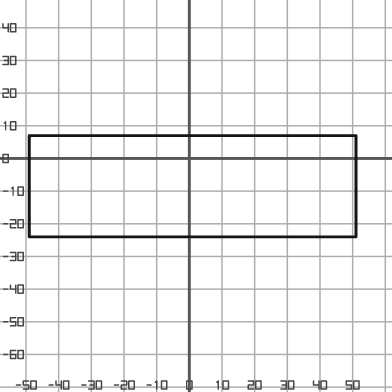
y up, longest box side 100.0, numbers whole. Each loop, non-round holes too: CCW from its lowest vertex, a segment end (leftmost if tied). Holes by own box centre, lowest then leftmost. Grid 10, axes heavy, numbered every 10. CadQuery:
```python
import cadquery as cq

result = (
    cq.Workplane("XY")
    .moveTo(-49.0, -24.0)
    .lineTo(51.0, -24.0)
    .lineTo(51.0, 7.0)
    .lineTo(-49.0, 7.0)
    .close()
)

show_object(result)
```